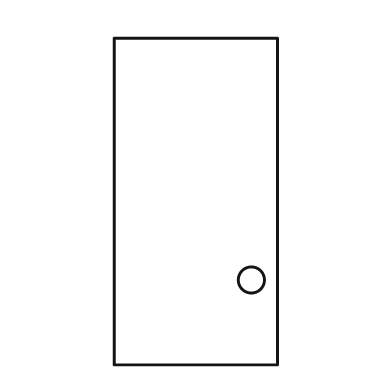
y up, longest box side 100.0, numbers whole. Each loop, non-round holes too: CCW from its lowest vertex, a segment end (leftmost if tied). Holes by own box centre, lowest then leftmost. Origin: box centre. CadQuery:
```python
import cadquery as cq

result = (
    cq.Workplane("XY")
    .moveTo(-25.0, -50.0)
    .lineTo(25.0, -50.0)
    .lineTo(25.0, 50.0)
    .lineTo(-25.0, 50.0)
    .close()
    .moveTo(17.0, -24.0)
    .circle(4.0)
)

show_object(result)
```